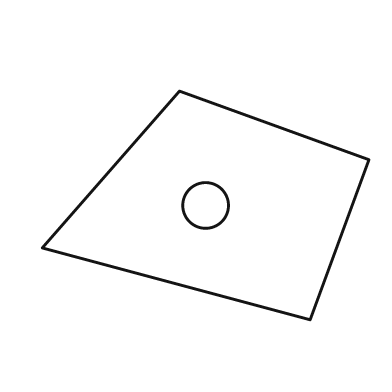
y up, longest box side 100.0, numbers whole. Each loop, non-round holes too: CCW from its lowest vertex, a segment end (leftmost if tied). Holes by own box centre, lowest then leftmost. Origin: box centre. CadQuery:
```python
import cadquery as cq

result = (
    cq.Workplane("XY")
    .moveTo(32.0, -35.0)
    .lineTo(50.0, 14.0)
    .lineTo(-8.0, 35.0)
    .lineTo(-50.0, -13.0)
    .close()
    .moveTo(0.0, 0.0)
    .circle(7.0)
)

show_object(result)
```